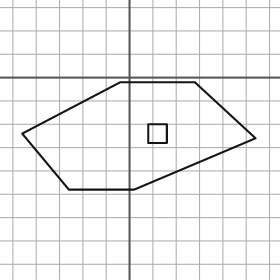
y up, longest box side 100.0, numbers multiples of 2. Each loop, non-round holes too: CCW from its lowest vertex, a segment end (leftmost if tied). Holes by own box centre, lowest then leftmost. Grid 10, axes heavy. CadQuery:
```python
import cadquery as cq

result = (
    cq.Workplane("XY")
    .moveTo(-26.0, -48.0)
    .lineTo(2.0, -48.0)
    .lineTo(54.0, -26.0)
    .lineTo(28.0, -2.0)
    .lineTo(-4.0, -2.0)
    .lineTo(-46.0, -24.0)
    .close()
    .moveTo(8.0, -28.0)
    .lineTo(16.0, -28.0)
    .lineTo(16.0, -20.0)
    .lineTo(8.0, -20.0)
    .close()
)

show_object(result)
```